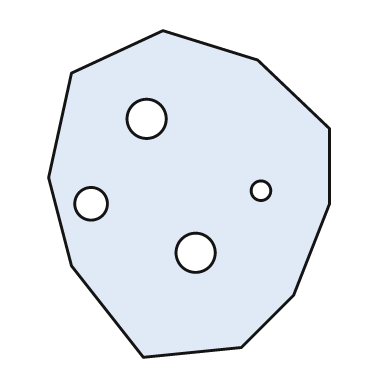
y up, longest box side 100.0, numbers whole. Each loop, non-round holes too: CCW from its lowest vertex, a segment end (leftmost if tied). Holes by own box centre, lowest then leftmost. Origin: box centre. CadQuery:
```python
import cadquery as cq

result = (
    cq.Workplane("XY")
    .moveTo(-14.0, -50.0)
    .lineTo(16.0, -47.0)
    .lineTo(32.0, -31.0)
    .lineTo(43.0, -3.0)
    .lineTo(43.0, 20.0)
    .lineTo(21.0, 41.0)
    .lineTo(-8.0, 50.0)
    .lineTo(-36.0, 37.0)
    .lineTo(-43.0, 5.0)
    .lineTo(-36.0, -22.0)
    .close()
    .moveTo(2.0, -18.0)
    .circle(6.0)
    .moveTo(-30.0, -3.0)
    .circle(5.0)
    .moveTo(22.0, 1.0)
    .circle(3.0)
    .moveTo(-13.0, 23.0)
    .circle(6.0)
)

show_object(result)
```